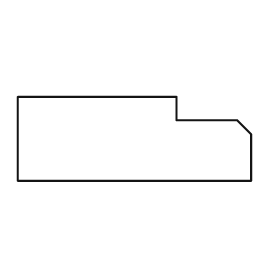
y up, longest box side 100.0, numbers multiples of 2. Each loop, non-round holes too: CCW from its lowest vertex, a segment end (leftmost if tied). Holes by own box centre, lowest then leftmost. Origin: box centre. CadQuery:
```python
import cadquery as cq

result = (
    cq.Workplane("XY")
    .moveTo(-50.0, -18.0)
    .lineTo(50.0, -18.0)
    .lineTo(50.0, 2.0)
    .lineTo(44.0, 8.0)
    .lineTo(18.0, 8.0)
    .lineTo(18.0, 18.0)
    .lineTo(-50.0, 18.0)
    .close()
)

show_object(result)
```